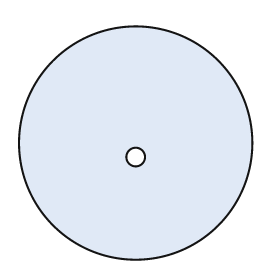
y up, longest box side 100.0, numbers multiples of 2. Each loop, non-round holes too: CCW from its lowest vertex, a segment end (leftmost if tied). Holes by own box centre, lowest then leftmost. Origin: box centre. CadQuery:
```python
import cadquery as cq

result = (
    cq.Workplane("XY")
    .moveTo(0.0, 0.0)
    .circle(50.0)
    .moveTo(0.0, -6.0)
    .circle(4.0)
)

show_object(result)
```